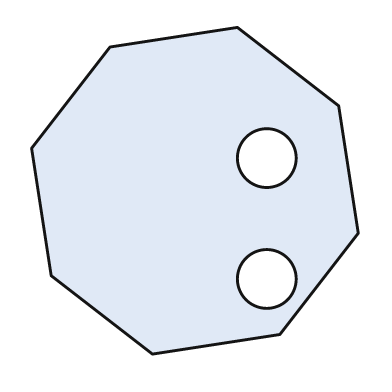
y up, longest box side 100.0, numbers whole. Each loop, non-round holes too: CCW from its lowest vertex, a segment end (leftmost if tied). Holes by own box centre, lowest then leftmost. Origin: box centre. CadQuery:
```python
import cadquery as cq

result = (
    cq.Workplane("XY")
    .moveTo(-13.0, -50.0)
    .lineTo(26.0, -44.0)
    .lineTo(50.0, -13.0)
    .lineTo(44.0, 26.0)
    .lineTo(13.0, 50.0)
    .lineTo(-26.0, 44.0)
    .lineTo(-50.0, 13.0)
    .lineTo(-44.0, -26.0)
    .close()
    .moveTo(22.0, -27.0)
    .circle(9.0)
    .moveTo(22.0, 10.0)
    .circle(9.0)
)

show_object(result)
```